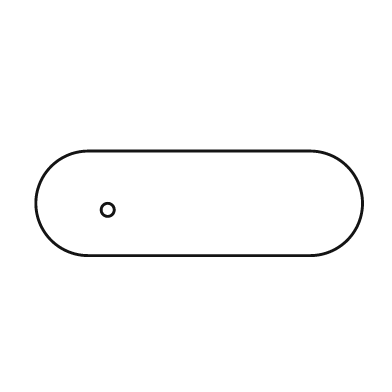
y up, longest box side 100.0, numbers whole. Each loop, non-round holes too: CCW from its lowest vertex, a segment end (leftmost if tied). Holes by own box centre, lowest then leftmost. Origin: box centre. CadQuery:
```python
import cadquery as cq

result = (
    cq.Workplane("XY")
    .moveTo(-34.0, -16.0)
    .lineTo(34.0, -16.0)
    .threePointArc((50.0, 0.0), (34.0, 16.0))
    .lineTo(-34.0, 16.0)
    .threePointArc((-50.0, 0.0), (-34.0, -16.0))
    .close()
    .moveTo(-28.0, -2.0)
    .circle(2.0)
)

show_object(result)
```